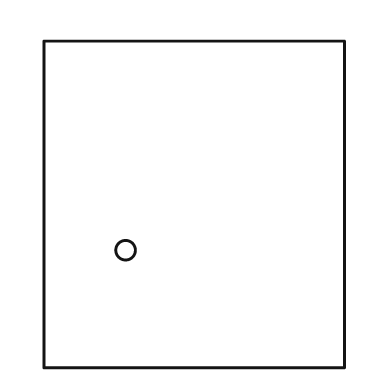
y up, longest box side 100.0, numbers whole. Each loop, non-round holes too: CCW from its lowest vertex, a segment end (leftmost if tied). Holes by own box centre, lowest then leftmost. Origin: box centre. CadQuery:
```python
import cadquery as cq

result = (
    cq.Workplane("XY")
    .moveTo(-46.0, -50.0)
    .lineTo(46.0, -50.0)
    .lineTo(46.0, 50.0)
    .lineTo(-46.0, 50.0)
    .close()
    .moveTo(-21.0, -14.0)
    .circle(3.0)
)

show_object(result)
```